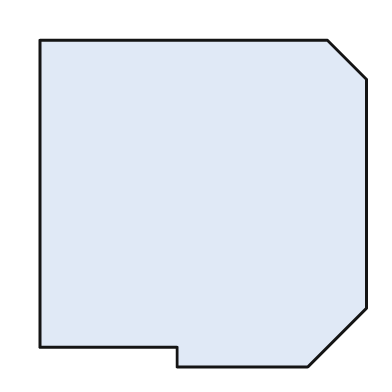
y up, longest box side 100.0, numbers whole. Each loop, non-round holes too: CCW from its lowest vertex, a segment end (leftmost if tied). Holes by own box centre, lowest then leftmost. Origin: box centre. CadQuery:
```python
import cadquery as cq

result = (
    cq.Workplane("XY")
    .moveTo(-8.0, -50.0)
    .lineTo(32.0, -50.0)
    .lineTo(50.0, -32.0)
    .lineTo(50.0, 38.0)
    .lineTo(38.0, 50.0)
    .lineTo(-50.0, 50.0)
    .lineTo(-50.0, -44.0)
    .lineTo(-8.0, -44.0)
    .close()
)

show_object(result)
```